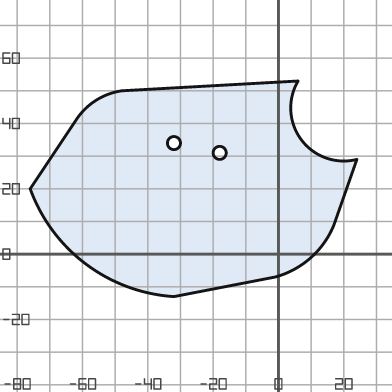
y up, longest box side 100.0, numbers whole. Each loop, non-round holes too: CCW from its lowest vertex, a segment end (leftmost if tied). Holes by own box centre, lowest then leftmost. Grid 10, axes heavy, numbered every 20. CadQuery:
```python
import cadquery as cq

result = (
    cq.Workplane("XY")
    .moveTo(-32.0, -13.0)
    .lineTo(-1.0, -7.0)
    .threePointArc((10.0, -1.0), (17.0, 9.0))
    .lineTo(24.0, 29.0)
    .threePointArc((7.0, 35.0), (6.0, 53.0))
    .lineTo(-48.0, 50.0)
    .threePointArc((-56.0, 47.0), (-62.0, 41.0))
    .lineTo(-76.0, 20.0)
    .threePointArc((-59.0, -3.0), (-32.0, -13.0))
    .close()
    .moveTo(-18.0, 31.0)
    .circle(2.0)
    .moveTo(-32.0, 34.0)
    .circle(2.0)
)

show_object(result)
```